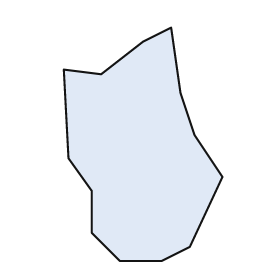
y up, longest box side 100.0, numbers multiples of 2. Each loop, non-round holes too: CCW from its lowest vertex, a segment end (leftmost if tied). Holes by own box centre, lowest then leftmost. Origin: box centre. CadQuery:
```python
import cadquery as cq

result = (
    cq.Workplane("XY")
    .moveTo(-10.0, -50.0)
    .lineTo(8.0, -50.0)
    .lineTo(20.0, -44.0)
    .lineTo(34.0, -14.0)
    .lineTo(22.0, 4.0)
    .lineTo(16.0, 22.0)
    .lineTo(12.0, 50.0)
    .lineTo(0.0, 44.0)
    .lineTo(-18.0, 30.0)
    .lineTo(-34.0, 32.0)
    .lineTo(-32.0, -6.0)
    .lineTo(-22.0, -20.0)
    .lineTo(-22.0, -38.0)
    .close()
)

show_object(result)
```